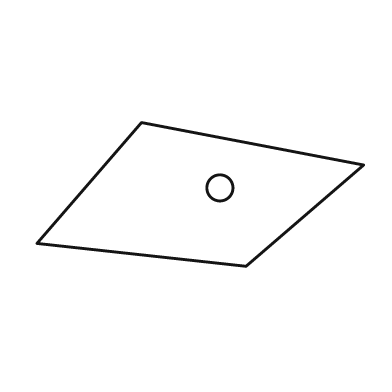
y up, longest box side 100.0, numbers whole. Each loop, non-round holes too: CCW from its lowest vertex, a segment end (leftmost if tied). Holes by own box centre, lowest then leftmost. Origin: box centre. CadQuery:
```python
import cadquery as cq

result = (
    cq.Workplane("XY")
    .moveTo(14.0, -22.0)
    .lineTo(50.0, 9.0)
    .lineTo(-18.0, 22.0)
    .lineTo(-50.0, -15.0)
    .close()
    .moveTo(6.0, 2.0)
    .circle(4.0)
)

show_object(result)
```